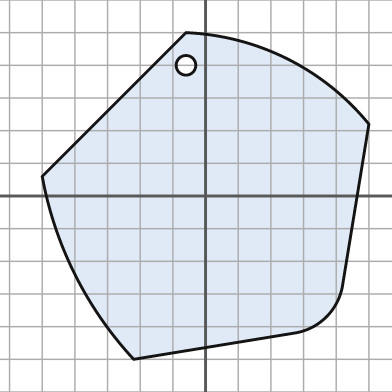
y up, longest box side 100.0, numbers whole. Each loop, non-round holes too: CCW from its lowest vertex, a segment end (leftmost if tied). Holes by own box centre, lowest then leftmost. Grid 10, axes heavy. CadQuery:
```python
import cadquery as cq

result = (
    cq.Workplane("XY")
    .moveTo(-22.0, -50.0)
    .lineTo(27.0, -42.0)
    .threePointArc((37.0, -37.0), (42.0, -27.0))
    .lineTo(50.0, 22.0)
    .threePointArc((25.0, 42.0), (-6.0, 50.0))
    .lineTo(-50.0, 6.0)
    .threePointArc((-40.0, -24.0), (-22.0, -50.0))
    .close()
    .moveTo(-6.0, 40.0)
    .circle(3.0)
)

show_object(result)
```